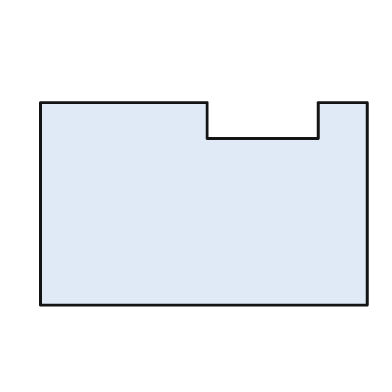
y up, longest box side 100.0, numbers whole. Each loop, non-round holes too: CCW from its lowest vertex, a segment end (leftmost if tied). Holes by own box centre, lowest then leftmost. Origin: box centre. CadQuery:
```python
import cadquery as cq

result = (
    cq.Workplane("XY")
    .moveTo(-50.0, -31.0)
    .lineTo(50.0, -31.0)
    .lineTo(50.0, 31.0)
    .lineTo(35.0, 31.0)
    .lineTo(35.0, 20.0)
    .lineTo(1.0, 20.0)
    .lineTo(1.0, 31.0)
    .lineTo(-50.0, 31.0)
    .close()
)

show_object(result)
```